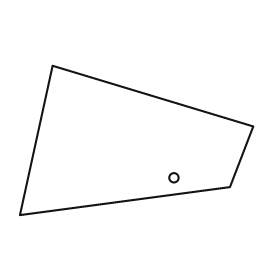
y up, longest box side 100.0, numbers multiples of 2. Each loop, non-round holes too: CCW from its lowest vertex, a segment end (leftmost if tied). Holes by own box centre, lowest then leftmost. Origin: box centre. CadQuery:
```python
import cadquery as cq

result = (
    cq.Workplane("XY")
    .moveTo(-50.0, -32.0)
    .lineTo(40.0, -20.0)
    .lineTo(50.0, 6.0)
    .lineTo(-36.0, 32.0)
    .close()
    .moveTo(16.0, -16.0)
    .circle(2.0)
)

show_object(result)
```